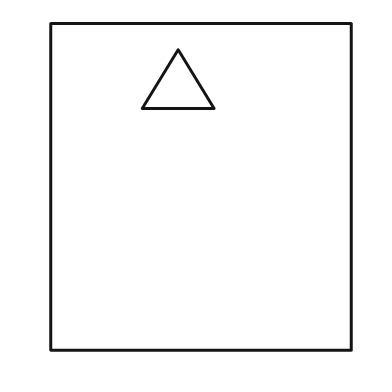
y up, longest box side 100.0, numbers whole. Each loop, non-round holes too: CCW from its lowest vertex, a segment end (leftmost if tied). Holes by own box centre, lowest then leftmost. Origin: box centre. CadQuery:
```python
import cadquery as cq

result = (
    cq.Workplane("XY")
    .moveTo(-46.0, -50.0)
    .lineTo(46.0, -50.0)
    .lineTo(46.0, 50.0)
    .lineTo(-46.0, 50.0)
    .close()
    .moveTo(-18.0, 24.0)
    .lineTo(4.0, 24.0)
    .lineTo(-7.0, 42.0)
    .close()
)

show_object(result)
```